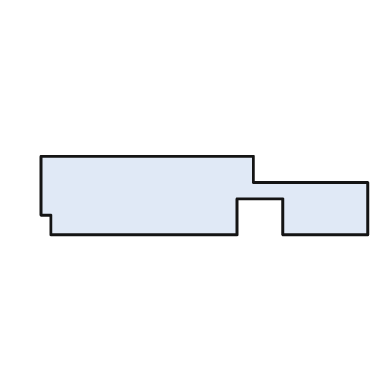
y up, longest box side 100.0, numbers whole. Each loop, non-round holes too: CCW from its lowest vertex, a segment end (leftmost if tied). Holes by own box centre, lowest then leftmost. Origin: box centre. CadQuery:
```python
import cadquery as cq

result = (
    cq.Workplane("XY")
    .moveTo(-47.0, -12.0)
    .lineTo(10.0, -12.0)
    .lineTo(10.0, -1.0)
    .lineTo(24.0, -1.0)
    .lineTo(24.0, -12.0)
    .lineTo(50.0, -12.0)
    .lineTo(50.0, 4.0)
    .lineTo(15.0, 4.0)
    .lineTo(15.0, 12.0)
    .lineTo(-50.0, 12.0)
    .lineTo(-50.0, -6.0)
    .lineTo(-47.0, -6.0)
    .close()
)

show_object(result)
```